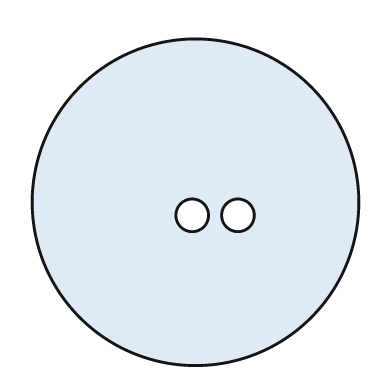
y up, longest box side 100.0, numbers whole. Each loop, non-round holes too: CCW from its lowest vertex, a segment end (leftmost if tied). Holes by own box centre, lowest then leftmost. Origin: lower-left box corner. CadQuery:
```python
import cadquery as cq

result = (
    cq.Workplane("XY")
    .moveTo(50.0, 50.0)
    .circle(50.0)
    .moveTo(49.0, 46.0)
    .circle(5.0)
    .moveTo(63.0, 46.0)
    .circle(5.0)
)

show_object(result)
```